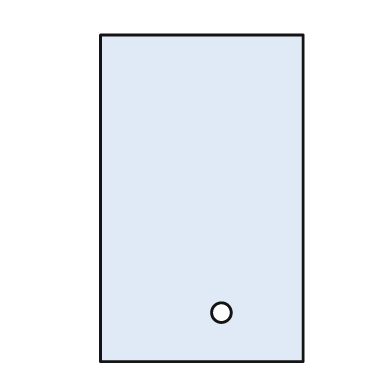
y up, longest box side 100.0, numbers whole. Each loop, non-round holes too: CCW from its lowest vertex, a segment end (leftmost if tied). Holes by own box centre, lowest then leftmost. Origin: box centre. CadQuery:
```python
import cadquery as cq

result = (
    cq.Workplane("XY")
    .moveTo(-31.0, -50.0)
    .lineTo(31.0, -50.0)
    .lineTo(31.0, 50.0)
    .lineTo(-31.0, 50.0)
    .close()
    .moveTo(6.0, -35.0)
    .circle(3.0)
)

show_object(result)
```